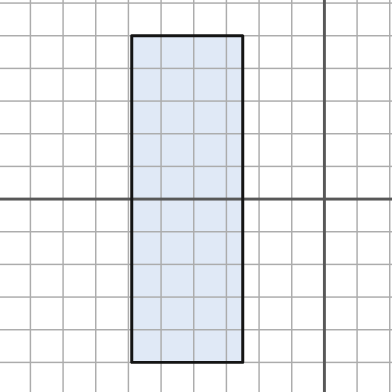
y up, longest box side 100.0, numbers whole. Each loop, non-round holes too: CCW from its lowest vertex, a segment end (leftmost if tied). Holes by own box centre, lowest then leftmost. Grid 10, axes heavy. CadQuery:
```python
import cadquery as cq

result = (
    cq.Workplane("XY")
    .moveTo(-59.0, -50.0)
    .lineTo(-25.0, -50.0)
    .lineTo(-25.0, 50.0)
    .lineTo(-59.0, 50.0)
    .close()
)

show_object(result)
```